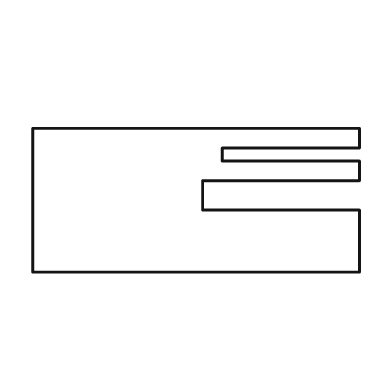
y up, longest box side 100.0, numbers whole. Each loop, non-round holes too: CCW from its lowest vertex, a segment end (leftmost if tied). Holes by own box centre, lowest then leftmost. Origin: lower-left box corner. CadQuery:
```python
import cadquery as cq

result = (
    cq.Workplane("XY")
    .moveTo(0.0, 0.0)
    .lineTo(100.0, 0.0)
    .lineTo(100.0, 19.0)
    .lineTo(52.0, 19.0)
    .lineTo(52.0, 28.0)
    .lineTo(100.0, 28.0)
    .lineTo(100.0, 34.0)
    .lineTo(58.0, 34.0)
    .lineTo(58.0, 38.0)
    .lineTo(100.0, 38.0)
    .lineTo(100.0, 44.0)
    .lineTo(0.0, 44.0)
    .close()
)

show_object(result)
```